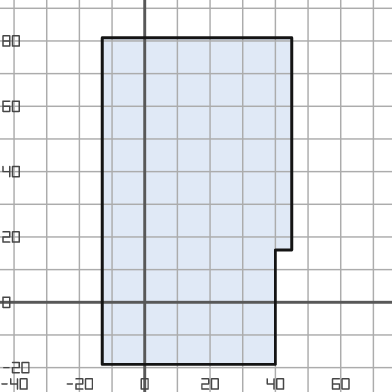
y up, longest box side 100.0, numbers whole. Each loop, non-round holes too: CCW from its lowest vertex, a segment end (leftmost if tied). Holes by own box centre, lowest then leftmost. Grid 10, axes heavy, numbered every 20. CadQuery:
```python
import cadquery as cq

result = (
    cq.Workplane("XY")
    .moveTo(-13.0, -19.0)
    .lineTo(40.0, -19.0)
    .lineTo(40.0, 16.0)
    .lineTo(45.0, 16.0)
    .lineTo(45.0, 81.0)
    .lineTo(-13.0, 81.0)
    .close()
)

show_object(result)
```